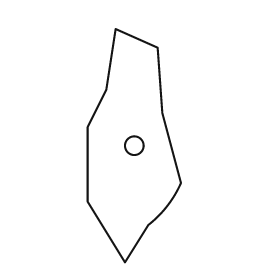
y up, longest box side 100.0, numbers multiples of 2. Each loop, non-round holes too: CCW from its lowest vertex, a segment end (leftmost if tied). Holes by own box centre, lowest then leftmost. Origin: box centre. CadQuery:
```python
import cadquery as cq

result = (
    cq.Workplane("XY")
    .moveTo(-4.0, -50.0)
    .lineTo(6.0, -34.0)
    .threePointArc((14.0, -26.0), (20.0, -16.0))
    .lineTo(12.0, 14.0)
    .lineTo(10.0, 42.0)
    .lineTo(-8.0, 50.0)
    .lineTo(-12.0, 24.0)
    .lineTo(-20.0, 8.0)
    .lineTo(-20.0, -24.0)
    .close()
    .moveTo(0.0, 0.0)
    .circle(4.0)
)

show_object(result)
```